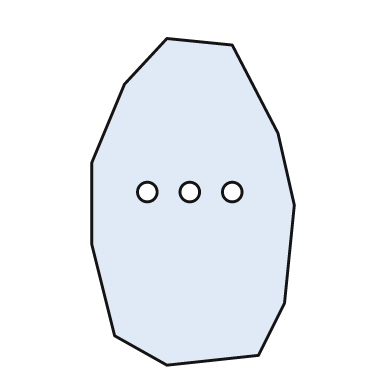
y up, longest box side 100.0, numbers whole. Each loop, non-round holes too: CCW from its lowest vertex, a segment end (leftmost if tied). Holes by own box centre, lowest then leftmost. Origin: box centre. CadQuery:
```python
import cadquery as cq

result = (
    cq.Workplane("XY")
    .moveTo(-8.0, -50.0)
    .lineTo(20.0, -47.0)
    .lineTo(28.0, -31.0)
    .lineTo(31.0, -1.0)
    .lineTo(26.0, 21.0)
    .lineTo(12.0, 48.0)
    .lineTo(-8.0, 50.0)
    .lineTo(-21.0, 36.0)
    .lineTo(-31.0, 12.0)
    .lineTo(-31.0, -13.0)
    .lineTo(-24.0, -41.0)
    .close()
    .moveTo(-14.0, 3.0)
    .circle(3.0)
    .moveTo(-1.0, 3.0)
    .circle(3.0)
    .moveTo(12.0, 3.0)
    .circle(3.0)
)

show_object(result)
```